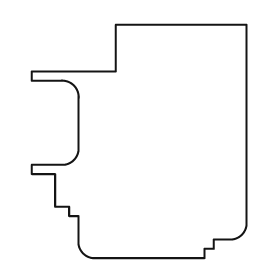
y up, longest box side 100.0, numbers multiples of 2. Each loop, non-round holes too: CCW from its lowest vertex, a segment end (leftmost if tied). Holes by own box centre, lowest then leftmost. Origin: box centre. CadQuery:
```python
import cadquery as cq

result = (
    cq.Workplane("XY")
    .moveTo(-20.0, -50.0)
    .lineTo(28.0, -50.0)
    .lineTo(28.0, -46.0)
    .lineTo(32.0, -46.0)
    .lineTo(32.0, -42.0)
    .lineTo(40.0, -42.0)
    .threePointArc((44.0, -40.0), (46.0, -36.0))
    .lineTo(46.0, 50.0)
    .lineTo(-10.0, 50.0)
    .lineTo(-10.0, 30.0)
    .lineTo(-46.0, 30.0)
    .lineTo(-46.0, 26.0)
    .lineTo(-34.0, 26.0)
    .threePointArc((-28.0, 24.0), (-26.0, 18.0))
    .lineTo(-26.0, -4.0)
    .threePointArc((-28.0, -8.0), (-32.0, -10.0))
    .lineTo(-46.0, -10.0)
    .lineTo(-46.0, -14.0)
    .lineTo(-36.0, -14.0)
    .lineTo(-36.0, -28.0)
    .lineTo(-30.0, -28.0)
    .lineTo(-30.0, -32.0)
    .lineTo(-26.0, -32.0)
    .lineTo(-26.0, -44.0)
    .threePointArc((-24.0, -48.0), (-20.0, -50.0))
    .close()
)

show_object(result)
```